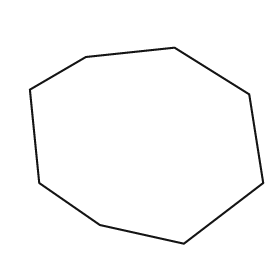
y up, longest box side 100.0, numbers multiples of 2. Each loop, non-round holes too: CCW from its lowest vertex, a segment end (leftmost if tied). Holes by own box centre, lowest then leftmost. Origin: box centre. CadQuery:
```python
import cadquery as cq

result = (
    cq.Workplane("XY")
    .moveTo(16.0, -42.0)
    .lineTo(50.0, -16.0)
    .lineTo(44.0, 22.0)
    .lineTo(12.0, 42.0)
    .lineTo(-26.0, 38.0)
    .lineTo(-50.0, 24.0)
    .lineTo(-46.0, -16.0)
    .lineTo(-20.0, -34.0)
    .close()
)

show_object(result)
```